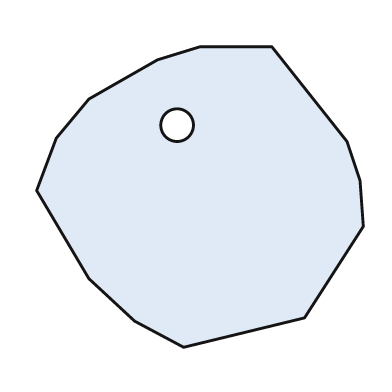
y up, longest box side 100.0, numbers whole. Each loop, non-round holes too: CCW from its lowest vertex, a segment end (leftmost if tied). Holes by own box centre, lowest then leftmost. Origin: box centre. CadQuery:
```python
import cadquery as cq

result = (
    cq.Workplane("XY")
    .moveTo(-5.0, -46.0)
    .lineTo(32.0, -37.0)
    .lineTo(50.0, -9.0)
    .lineTo(49.0, 5.0)
    .lineTo(45.0, 17.0)
    .lineTo(22.0, 46.0)
    .lineTo(0.0, 46.0)
    .lineTo(-13.0, 42.0)
    .lineTo(-34.0, 30.0)
    .lineTo(-44.0, 18.0)
    .lineTo(-50.0, 2.0)
    .lineTo(-34.0, -25.0)
    .lineTo(-20.0, -38.0)
    .close()
    .moveTo(-7.0, 22.0)
    .circle(5.0)
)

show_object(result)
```